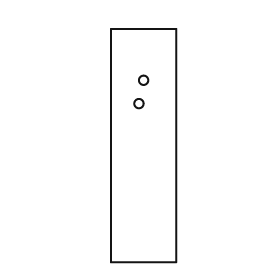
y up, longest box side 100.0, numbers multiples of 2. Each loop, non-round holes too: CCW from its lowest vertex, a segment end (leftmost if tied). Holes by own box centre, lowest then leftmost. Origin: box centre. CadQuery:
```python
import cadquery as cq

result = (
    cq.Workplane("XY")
    .moveTo(-14.0, -50.0)
    .lineTo(14.0, -50.0)
    .lineTo(14.0, 50.0)
    .lineTo(-14.0, 50.0)
    .close()
    .moveTo(-2.0, 18.0)
    .circle(2.0)
    .moveTo(0.0, 28.0)
    .circle(2.0)
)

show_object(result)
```